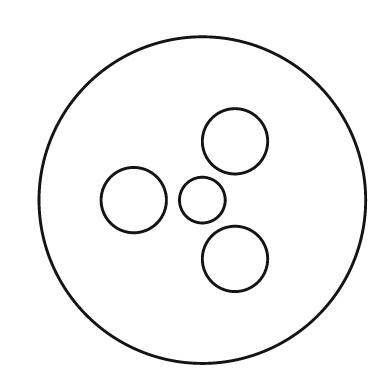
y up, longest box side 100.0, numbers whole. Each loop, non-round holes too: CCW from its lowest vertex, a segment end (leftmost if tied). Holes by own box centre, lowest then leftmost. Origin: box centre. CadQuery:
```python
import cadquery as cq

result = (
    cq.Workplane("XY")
    .moveTo(0.0, 0.0)
    .circle(50.0)
    .moveTo(10.0, -18.0)
    .circle(10.0)
    .moveTo(-21.0, 0.0)
    .circle(10.0)
    .moveTo(0.0, 0.0)
    .circle(7.0)
    .moveTo(10.0, 18.0)
    .circle(10.0)
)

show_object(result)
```